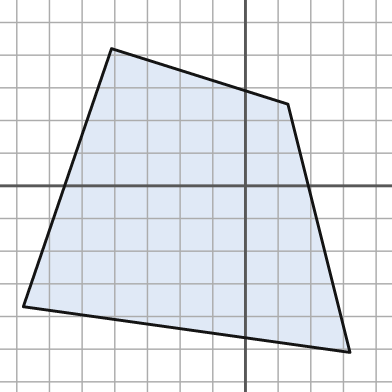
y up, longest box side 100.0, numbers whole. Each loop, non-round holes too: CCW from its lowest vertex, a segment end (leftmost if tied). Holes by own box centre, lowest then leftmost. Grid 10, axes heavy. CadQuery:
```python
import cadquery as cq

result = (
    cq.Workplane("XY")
    .moveTo(32.0, -51.0)
    .lineTo(13.0, 25.0)
    .lineTo(-41.0, 42.0)
    .lineTo(-68.0, -37.0)
    .close()
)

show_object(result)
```